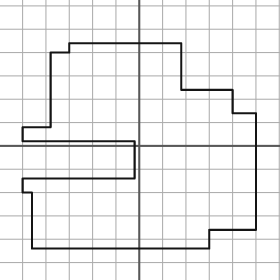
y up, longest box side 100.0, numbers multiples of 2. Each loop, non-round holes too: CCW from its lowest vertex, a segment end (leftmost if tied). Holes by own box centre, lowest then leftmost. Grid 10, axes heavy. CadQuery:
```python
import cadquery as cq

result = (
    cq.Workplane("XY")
    .moveTo(-46.0, -44.0)
    .lineTo(30.0, -44.0)
    .lineTo(30.0, -36.0)
    .lineTo(50.0, -36.0)
    .lineTo(50.0, 14.0)
    .lineTo(40.0, 14.0)
    .lineTo(40.0, 24.0)
    .lineTo(18.0, 24.0)
    .lineTo(18.0, 44.0)
    .lineTo(-30.0, 44.0)
    .lineTo(-30.0, 40.0)
    .lineTo(-38.0, 40.0)
    .lineTo(-38.0, 8.0)
    .lineTo(-50.0, 8.0)
    .lineTo(-50.0, 2.0)
    .lineTo(-2.0, 2.0)
    .lineTo(-2.0, -14.0)
    .lineTo(-50.0, -14.0)
    .lineTo(-50.0, -20.0)
    .lineTo(-46.0, -20.0)
    .close()
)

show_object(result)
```